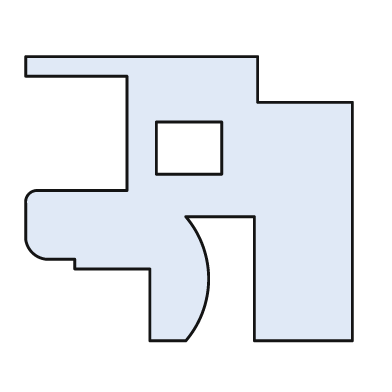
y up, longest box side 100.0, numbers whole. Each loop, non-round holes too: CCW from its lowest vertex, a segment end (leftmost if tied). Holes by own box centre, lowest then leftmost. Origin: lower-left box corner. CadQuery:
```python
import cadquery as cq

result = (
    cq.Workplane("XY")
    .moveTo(38.0, 0.0)
    .lineTo(49.0, 0.0)
    .threePointArc((56.0, 19.0), (49.0, 38.0))
    .lineTo(70.0, 38.0)
    .lineTo(70.0, 0.0)
    .lineTo(100.0, 0.0)
    .lineTo(100.0, 73.0)
    .lineTo(71.0, 73.0)
    .lineTo(71.0, 87.0)
    .lineTo(0.0, 87.0)
    .lineTo(0.0, 81.0)
    .lineTo(31.0, 81.0)
    .lineTo(31.0, 46.0)
    .lineTo(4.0, 46.0)
    .threePointArc((1.0, 45.0), (0.0, 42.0))
    .lineTo(0.0, 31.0)
    .threePointArc((2.0, 27.0), (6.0, 25.0))
    .lineTo(15.0, 25.0)
    .lineTo(15.0, 22.0)
    .lineTo(38.0, 22.0)
    .close()
    .moveTo(40.0, 51.0)
    .lineTo(60.0, 51.0)
    .lineTo(60.0, 67.0)
    .lineTo(40.0, 67.0)
    .close()
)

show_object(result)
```